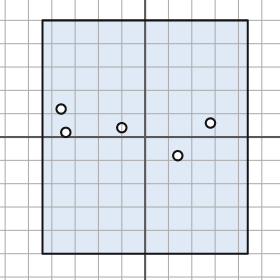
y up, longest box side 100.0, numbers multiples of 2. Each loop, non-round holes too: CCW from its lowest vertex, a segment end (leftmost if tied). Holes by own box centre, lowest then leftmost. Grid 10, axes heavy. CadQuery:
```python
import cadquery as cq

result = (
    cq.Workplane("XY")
    .moveTo(-44.0, -50.0)
    .lineTo(44.0, -50.0)
    .lineTo(44.0, 50.0)
    .lineTo(-44.0, 50.0)
    .close()
    .moveTo(14.0, -8.0)
    .circle(2.0)
    .moveTo(-34.0, 2.0)
    .circle(2.0)
    .moveTo(-10.0, 4.0)
    .circle(2.0)
    .moveTo(28.0, 6.0)
    .circle(2.0)
    .moveTo(-36.0, 12.0)
    .circle(2.0)
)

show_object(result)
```